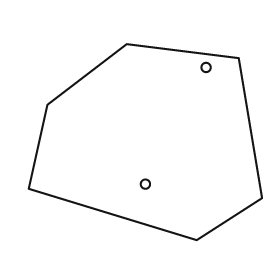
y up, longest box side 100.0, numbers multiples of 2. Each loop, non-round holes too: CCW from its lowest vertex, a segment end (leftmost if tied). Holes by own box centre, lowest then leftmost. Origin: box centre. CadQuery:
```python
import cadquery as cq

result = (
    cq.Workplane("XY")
    .moveTo(22.0, -42.0)
    .lineTo(50.0, -24.0)
    .lineTo(40.0, 36.0)
    .lineTo(-8.0, 42.0)
    .lineTo(-42.0, 16.0)
    .lineTo(-50.0, -20.0)
    .close()
    .moveTo(0.0, -18.0)
    .circle(2.0)
    .moveTo(26.0, 32.0)
    .circle(2.0)
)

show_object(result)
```